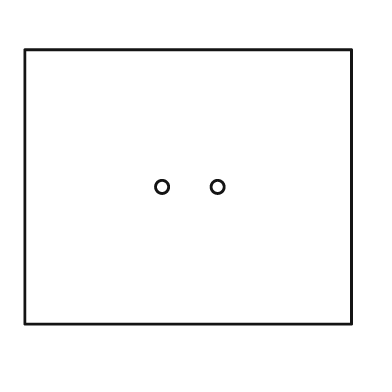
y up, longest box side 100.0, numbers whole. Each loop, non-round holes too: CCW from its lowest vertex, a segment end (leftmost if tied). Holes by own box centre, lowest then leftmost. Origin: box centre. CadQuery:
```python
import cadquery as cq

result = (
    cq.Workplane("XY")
    .moveTo(-50.0, -42.0)
    .lineTo(50.0, -42.0)
    .lineTo(50.0, 42.0)
    .lineTo(-50.0, 42.0)
    .close()
    .moveTo(-8.0, 0.0)
    .circle(2.0)
    .moveTo(9.0, 0.0)
    .circle(2.0)
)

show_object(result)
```